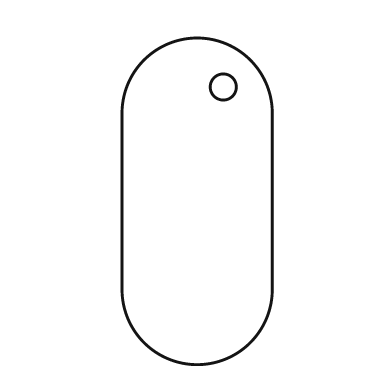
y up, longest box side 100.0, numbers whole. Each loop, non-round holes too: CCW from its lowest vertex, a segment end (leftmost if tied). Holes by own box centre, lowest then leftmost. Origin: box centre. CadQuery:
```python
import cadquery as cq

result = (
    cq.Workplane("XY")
    .moveTo(-23.0, -27.0)
    .threePointArc((0.0, -50.0), (23.0, -27.0))
    .lineTo(23.0, 27.0)
    .threePointArc((0.0, 50.0), (-23.0, 27.0))
    .close()
    .moveTo(8.0, 35.0)
    .circle(4.0)
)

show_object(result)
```